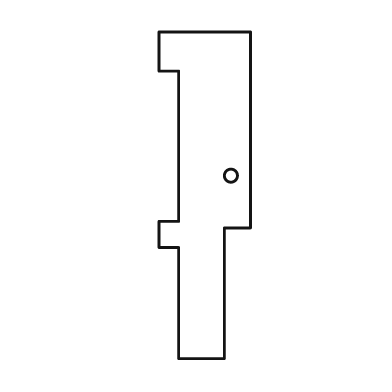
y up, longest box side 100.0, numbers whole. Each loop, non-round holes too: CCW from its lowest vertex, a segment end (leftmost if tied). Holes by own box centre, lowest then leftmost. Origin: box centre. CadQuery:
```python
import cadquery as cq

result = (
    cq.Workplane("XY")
    .moveTo(-8.0, -50.0)
    .lineTo(6.0, -50.0)
    .lineTo(6.0, -10.0)
    .lineTo(14.0, -10.0)
    .lineTo(14.0, 50.0)
    .lineTo(-14.0, 50.0)
    .lineTo(-14.0, 38.0)
    .lineTo(-8.0, 38.0)
    .lineTo(-8.0, -8.0)
    .lineTo(-14.0, -8.0)
    .lineTo(-14.0, -16.0)
    .lineTo(-8.0, -16.0)
    .close()
    .moveTo(8.0, 6.0)
    .circle(2.0)
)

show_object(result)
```